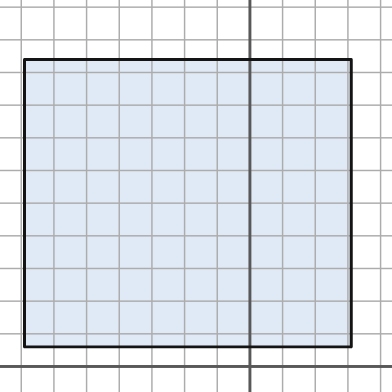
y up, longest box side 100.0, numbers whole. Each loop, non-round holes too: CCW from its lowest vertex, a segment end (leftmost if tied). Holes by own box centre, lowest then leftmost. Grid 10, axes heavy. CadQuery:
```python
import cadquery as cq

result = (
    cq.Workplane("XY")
    .moveTo(-69.0, 6.0)
    .lineTo(31.0, 6.0)
    .lineTo(31.0, 94.0)
    .lineTo(-69.0, 94.0)
    .close()
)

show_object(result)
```